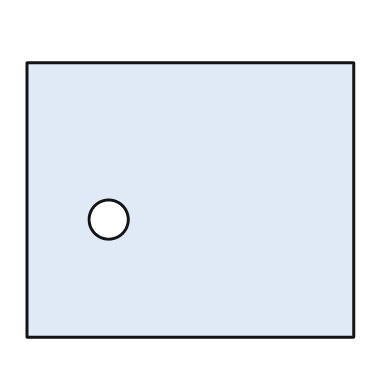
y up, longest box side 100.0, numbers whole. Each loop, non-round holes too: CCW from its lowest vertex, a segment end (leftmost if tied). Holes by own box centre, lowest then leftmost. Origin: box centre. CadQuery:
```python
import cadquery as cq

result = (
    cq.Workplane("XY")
    .moveTo(-50.0, -42.0)
    .lineTo(50.0, -42.0)
    .lineTo(50.0, 42.0)
    .lineTo(-50.0, 42.0)
    .close()
    .moveTo(-25.0, -6.0)
    .circle(6.0)
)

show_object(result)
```